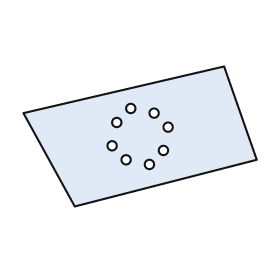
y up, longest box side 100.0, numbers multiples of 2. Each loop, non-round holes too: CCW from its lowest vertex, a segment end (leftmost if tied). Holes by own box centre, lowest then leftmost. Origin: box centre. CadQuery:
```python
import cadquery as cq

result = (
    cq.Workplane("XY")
    .moveTo(-28.0, -30.0)
    .lineTo(50.0, -10.0)
    .lineTo(36.0, 30.0)
    .lineTo(-50.0, 10.0)
    .close()
    .moveTo(4.0, -12.0)
    .circle(2.0)
    .moveTo(-6.0, -10.0)
    .circle(2.0)
    .moveTo(10.0, -6.0)
    .circle(2.0)
    .moveTo(-12.0, -4.0)
    .circle(2.0)
    .moveTo(12.0, 4.0)
    .circle(2.0)
    .moveTo(-10.0, 6.0)
    .circle(2.0)
    .moveTo(6.0, 10.0)
    .circle(2.0)
    .moveTo(-4.0, 12.0)
    .circle(2.0)
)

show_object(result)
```